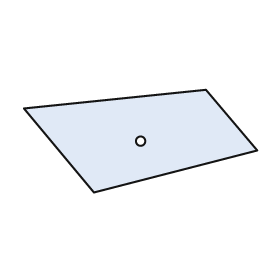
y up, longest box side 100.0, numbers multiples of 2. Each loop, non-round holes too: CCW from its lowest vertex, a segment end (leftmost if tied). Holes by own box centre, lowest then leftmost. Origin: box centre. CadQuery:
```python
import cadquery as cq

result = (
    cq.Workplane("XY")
    .moveTo(-20.0, -22.0)
    .lineTo(50.0, -4.0)
    .lineTo(28.0, 22.0)
    .lineTo(-50.0, 14.0)
    .close()
    .moveTo(0.0, 0.0)
    .circle(2.0)
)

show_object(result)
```